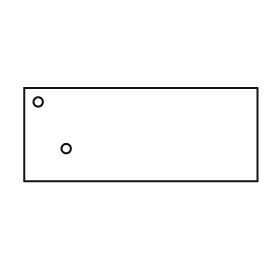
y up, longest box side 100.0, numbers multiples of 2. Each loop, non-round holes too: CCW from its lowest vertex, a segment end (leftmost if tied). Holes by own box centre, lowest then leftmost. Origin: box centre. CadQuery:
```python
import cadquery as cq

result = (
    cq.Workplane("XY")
    .moveTo(-50.0, -20.0)
    .lineTo(50.0, -20.0)
    .lineTo(50.0, 20.0)
    .lineTo(-50.0, 20.0)
    .close()
    .moveTo(-32.0, -6.0)
    .circle(2.0)
    .moveTo(-44.0, 14.0)
    .circle(2.0)
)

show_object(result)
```